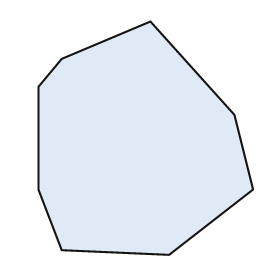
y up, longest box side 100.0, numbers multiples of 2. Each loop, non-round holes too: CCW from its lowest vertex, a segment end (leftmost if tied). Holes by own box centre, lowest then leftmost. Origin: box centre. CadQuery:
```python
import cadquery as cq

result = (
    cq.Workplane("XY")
    .moveTo(10.0, -50.0)
    .lineTo(46.0, -22.0)
    .lineTo(38.0, 10.0)
    .lineTo(2.0, 50.0)
    .lineTo(-36.0, 34.0)
    .lineTo(-46.0, 22.0)
    .lineTo(-46.0, -22.0)
    .lineTo(-36.0, -48.0)
    .close()
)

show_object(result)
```